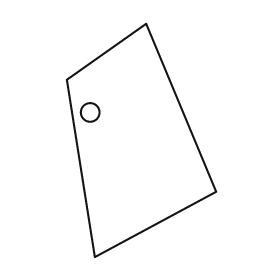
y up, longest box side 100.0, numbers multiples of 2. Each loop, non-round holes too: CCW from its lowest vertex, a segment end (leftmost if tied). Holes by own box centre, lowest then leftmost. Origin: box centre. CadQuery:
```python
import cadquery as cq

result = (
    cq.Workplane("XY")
    .moveTo(-20.0, -50.0)
    .lineTo(32.0, -22.0)
    .lineTo(2.0, 50.0)
    .lineTo(-32.0, 26.0)
    .close()
    .moveTo(-22.0, 12.0)
    .circle(4.0)
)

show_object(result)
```